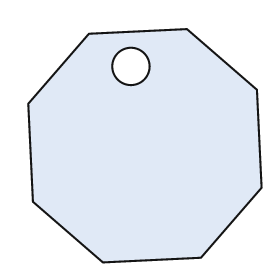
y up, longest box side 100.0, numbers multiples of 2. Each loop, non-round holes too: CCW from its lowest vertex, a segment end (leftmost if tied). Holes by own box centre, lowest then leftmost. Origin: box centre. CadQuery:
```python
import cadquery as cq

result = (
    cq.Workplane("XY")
    .moveTo(-18.0, -50.0)
    .lineTo(24.0, -48.0)
    .lineTo(50.0, -18.0)
    .lineTo(48.0, 24.0)
    .lineTo(18.0, 50.0)
    .lineTo(-24.0, 48.0)
    .lineTo(-50.0, 18.0)
    .lineTo(-48.0, -24.0)
    .close()
    .moveTo(-6.0, 34.0)
    .circle(8.0)
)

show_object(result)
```